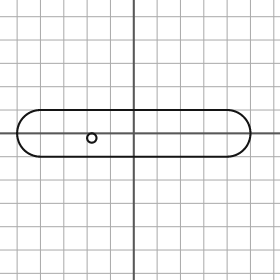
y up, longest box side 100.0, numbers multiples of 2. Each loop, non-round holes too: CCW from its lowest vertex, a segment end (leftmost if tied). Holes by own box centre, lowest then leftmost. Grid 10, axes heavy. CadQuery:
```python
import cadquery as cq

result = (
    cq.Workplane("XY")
    .moveTo(-40.0, -10.0)
    .lineTo(40.0, -10.0)
    .threePointArc((50.0, 0.0), (40.0, 10.0))
    .lineTo(-40.0, 10.0)
    .threePointArc((-50.0, 0.0), (-40.0, -10.0))
    .close()
    .moveTo(-18.0, -2.0)
    .circle(2.0)
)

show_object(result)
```